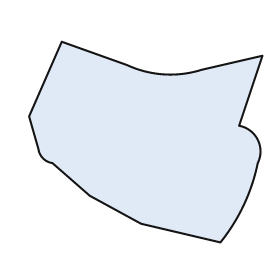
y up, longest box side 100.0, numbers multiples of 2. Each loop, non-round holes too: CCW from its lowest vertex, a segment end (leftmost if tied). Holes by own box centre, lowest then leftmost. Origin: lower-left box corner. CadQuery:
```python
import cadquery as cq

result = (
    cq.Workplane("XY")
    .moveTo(82.0, 0.0)
    .threePointArc((92.0, 16.0), (98.0, 34.0))
    .threePointArc((98.0, 44.0), (90.0, 50.0))
    .lineTo(100.0, 80.0)
    .lineTo(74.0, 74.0)
    .threePointArc((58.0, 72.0), (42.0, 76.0))
    .lineTo(14.0, 86.0)
    .lineTo(0.0, 54.0)
    .lineTo(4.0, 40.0)
    .threePointArc((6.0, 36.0), (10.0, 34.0))
    .lineTo(26.0, 20.0)
    .lineTo(48.0, 8.0)
    .close()
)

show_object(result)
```